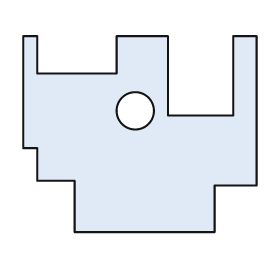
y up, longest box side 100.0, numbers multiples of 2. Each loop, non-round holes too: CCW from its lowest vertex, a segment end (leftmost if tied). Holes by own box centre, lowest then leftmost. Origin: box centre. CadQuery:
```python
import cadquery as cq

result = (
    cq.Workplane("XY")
    .moveTo(-28.0, -42.0)
    .lineTo(32.0, -42.0)
    .lineTo(32.0, -22.0)
    .lineTo(50.0, -22.0)
    .lineTo(50.0, 42.0)
    .lineTo(40.0, 42.0)
    .lineTo(40.0, 8.0)
    .lineTo(12.0, 8.0)
    .lineTo(12.0, 42.0)
    .lineTo(-10.0, 42.0)
    .lineTo(-10.0, 26.0)
    .lineTo(-44.0, 26.0)
    .lineTo(-44.0, 42.0)
    .lineTo(-50.0, 42.0)
    .lineTo(-50.0, -6.0)
    .lineTo(-44.0, -6.0)
    .lineTo(-44.0, -20.0)
    .lineTo(-28.0, -20.0)
    .close()
    .moveTo(-2.0, 10.0)
    .circle(8.0)
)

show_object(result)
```